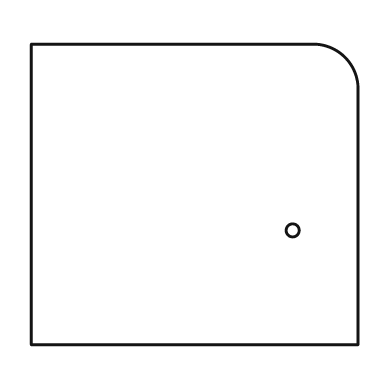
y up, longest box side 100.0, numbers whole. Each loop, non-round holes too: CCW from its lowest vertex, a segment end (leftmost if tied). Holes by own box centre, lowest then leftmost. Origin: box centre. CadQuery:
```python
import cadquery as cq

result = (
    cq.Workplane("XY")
    .moveTo(-50.0, -46.0)
    .lineTo(50.0, -46.0)
    .lineTo(50.0, 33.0)
    .threePointArc((46.0, 42.0), (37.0, 46.0))
    .lineTo(-50.0, 46.0)
    .close()
    .moveTo(30.0, -11.0)
    .circle(2.0)
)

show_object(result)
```